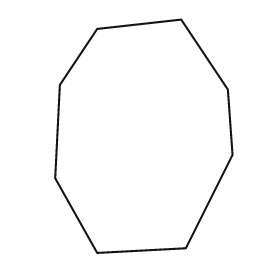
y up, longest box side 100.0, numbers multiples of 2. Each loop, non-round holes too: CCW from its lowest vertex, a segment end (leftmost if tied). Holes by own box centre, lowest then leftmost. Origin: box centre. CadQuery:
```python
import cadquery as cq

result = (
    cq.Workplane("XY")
    .moveTo(-20.0, -50.0)
    .lineTo(18.0, -48.0)
    .lineTo(38.0, -8.0)
    .lineTo(36.0, 20.0)
    .lineTo(16.0, 50.0)
    .lineTo(-20.0, 46.0)
    .lineTo(-36.0, 22.0)
    .lineTo(-38.0, -18.0)
    .close()
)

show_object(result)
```